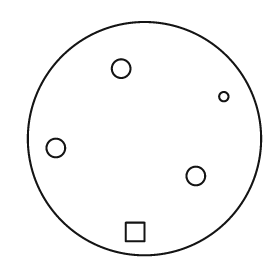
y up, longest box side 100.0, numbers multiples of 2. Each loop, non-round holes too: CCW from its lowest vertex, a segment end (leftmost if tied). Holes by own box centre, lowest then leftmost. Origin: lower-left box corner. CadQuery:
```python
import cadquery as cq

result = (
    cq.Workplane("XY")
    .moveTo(50.0, 50.0)
    .circle(50.0)
    .moveTo(42.0, 6.0)
    .lineTo(50.0, 6.0)
    .lineTo(50.0, 14.0)
    .lineTo(42.0, 14.0)
    .close()
    .moveTo(72.0, 34.0)
    .circle(4.0)
    .moveTo(12.0, 46.0)
    .circle(4.0)
    .moveTo(84.0, 68.0)
    .circle(2.0)
    .moveTo(40.0, 80.0)
    .circle(4.0)
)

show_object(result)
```